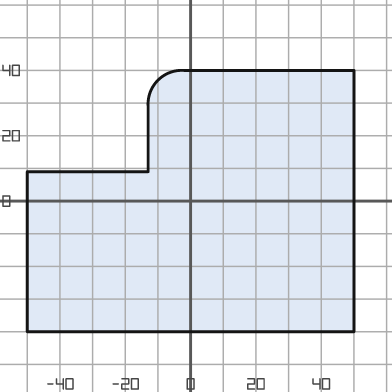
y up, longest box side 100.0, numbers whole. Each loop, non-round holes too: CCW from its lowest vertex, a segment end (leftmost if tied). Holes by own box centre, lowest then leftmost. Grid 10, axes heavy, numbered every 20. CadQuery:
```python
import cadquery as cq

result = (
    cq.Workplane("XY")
    .moveTo(-50.0, -40.0)
    .lineTo(50.0, -40.0)
    .lineTo(50.0, 40.0)
    .lineTo(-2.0, 40.0)
    .threePointArc((-10.0, 37.0), (-13.0, 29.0))
    .lineTo(-13.0, 9.0)
    .lineTo(-50.0, 9.0)
    .close()
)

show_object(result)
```